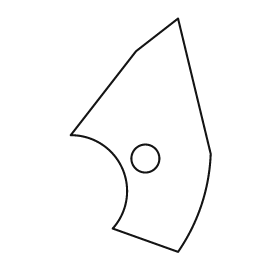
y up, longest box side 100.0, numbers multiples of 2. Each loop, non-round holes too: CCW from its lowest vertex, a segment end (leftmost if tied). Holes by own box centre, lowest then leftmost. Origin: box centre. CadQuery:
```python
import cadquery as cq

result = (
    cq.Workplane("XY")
    .moveTo(16.0, -50.0)
    .threePointArc((26.0, -30.0), (30.0, -8.0))
    .lineTo(16.0, 50.0)
    .lineTo(-2.0, 36.0)
    .lineTo(-30.0, 0.0)
    .threePointArc((-8.0, -14.0), (-12.0, -40.0))
    .close()
    .moveTo(2.0, -10.0)
    .circle(6.0)
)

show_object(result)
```